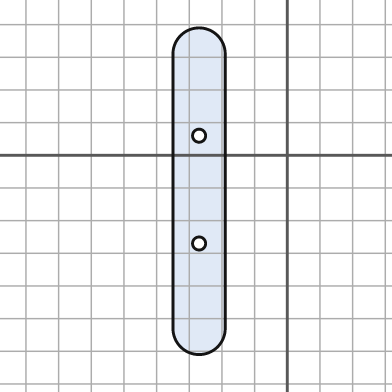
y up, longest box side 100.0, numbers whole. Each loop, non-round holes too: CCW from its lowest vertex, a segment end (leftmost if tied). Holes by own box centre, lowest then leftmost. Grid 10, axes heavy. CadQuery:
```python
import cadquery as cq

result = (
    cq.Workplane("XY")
    .moveTo(-35.0, -53.0)
    .threePointArc((-27.0, -61.0), (-19.0, -53.0))
    .lineTo(-19.0, 31.0)
    .threePointArc((-27.0, 39.0), (-35.0, 31.0))
    .close()
    .moveTo(-27.0, -27.0)
    .circle(2.0)
    .moveTo(-27.0, 6.0)
    .circle(2.0)
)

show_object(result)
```